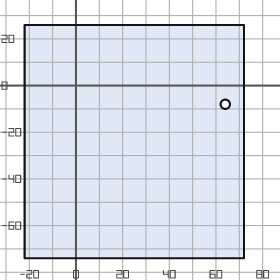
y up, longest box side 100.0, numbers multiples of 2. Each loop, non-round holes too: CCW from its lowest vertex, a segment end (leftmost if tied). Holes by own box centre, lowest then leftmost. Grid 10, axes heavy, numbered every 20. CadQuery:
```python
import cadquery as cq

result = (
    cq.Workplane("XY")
    .moveTo(-22.0, -74.0)
    .lineTo(72.0, -74.0)
    .lineTo(72.0, 26.0)
    .lineTo(-22.0, 26.0)
    .close()
    .moveTo(64.0, -8.0)
    .circle(2.0)
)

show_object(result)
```